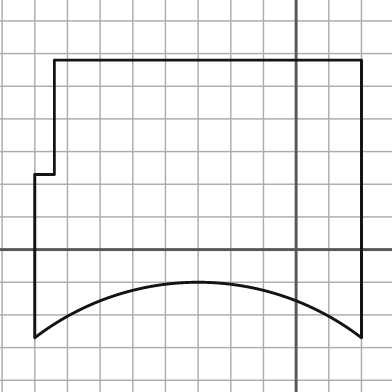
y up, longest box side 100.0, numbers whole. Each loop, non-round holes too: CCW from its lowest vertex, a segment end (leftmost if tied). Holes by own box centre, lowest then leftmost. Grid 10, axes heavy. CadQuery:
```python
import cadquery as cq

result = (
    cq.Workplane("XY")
    .moveTo(-80.0, -27.0)
    .threePointArc((-30.0, -10.0), (20.0, -27.0))
    .lineTo(20.0, 58.0)
    .lineTo(-74.0, 58.0)
    .lineTo(-74.0, 23.0)
    .lineTo(-80.0, 23.0)
    .close()
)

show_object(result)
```